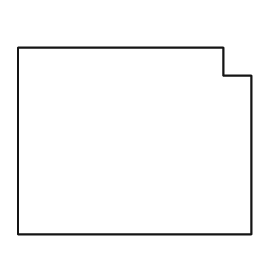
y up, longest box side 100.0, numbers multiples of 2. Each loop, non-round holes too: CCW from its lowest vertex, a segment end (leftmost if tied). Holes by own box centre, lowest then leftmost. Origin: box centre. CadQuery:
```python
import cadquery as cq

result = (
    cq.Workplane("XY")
    .moveTo(-50.0, -40.0)
    .lineTo(50.0, -40.0)
    .lineTo(50.0, 28.0)
    .lineTo(38.0, 28.0)
    .lineTo(38.0, 40.0)
    .lineTo(-50.0, 40.0)
    .close()
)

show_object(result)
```